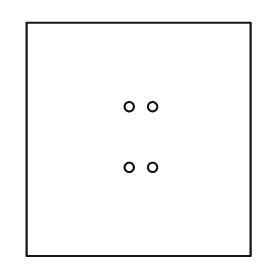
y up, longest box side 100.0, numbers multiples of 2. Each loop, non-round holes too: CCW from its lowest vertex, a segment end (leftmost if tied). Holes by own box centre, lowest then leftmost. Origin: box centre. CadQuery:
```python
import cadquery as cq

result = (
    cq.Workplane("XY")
    .moveTo(-48.0, -50.0)
    .lineTo(48.0, -50.0)
    .lineTo(48.0, 50.0)
    .lineTo(-48.0, 50.0)
    .close()
    .moveTo(-4.0, -12.0)
    .circle(2.0)
    .moveTo(6.0, -12.0)
    .circle(2.0)
    .moveTo(-4.0, 14.0)
    .circle(2.0)
    .moveTo(6.0, 14.0)
    .circle(2.0)
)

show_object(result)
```